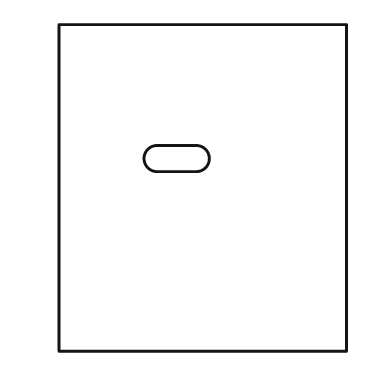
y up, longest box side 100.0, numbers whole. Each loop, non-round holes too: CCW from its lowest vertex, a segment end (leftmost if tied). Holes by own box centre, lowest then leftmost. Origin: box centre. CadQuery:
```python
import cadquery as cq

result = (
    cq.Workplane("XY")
    .moveTo(-44.0, -50.0)
    .lineTo(44.0, -50.0)
    .lineTo(44.0, 50.0)
    .lineTo(-44.0, 50.0)
    .close()
    .moveTo(-14.0, 5.0)
    .lineTo(-2.0, 5.0)
    .threePointArc((2.0, 9.0), (-2.0, 13.0))
    .lineTo(-14.0, 13.0)
    .threePointArc((-18.0, 9.0), (-14.0, 5.0))
    .close()
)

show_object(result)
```